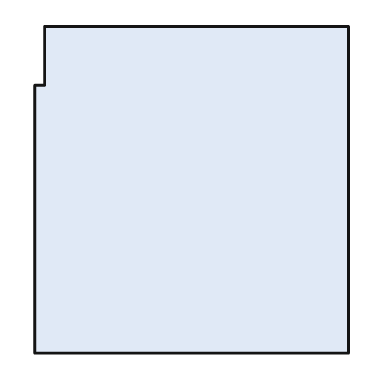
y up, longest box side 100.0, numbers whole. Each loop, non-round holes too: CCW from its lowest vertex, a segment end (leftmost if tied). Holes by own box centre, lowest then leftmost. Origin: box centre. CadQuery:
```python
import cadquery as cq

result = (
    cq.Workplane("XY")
    .moveTo(-48.0, -50.0)
    .lineTo(48.0, -50.0)
    .lineTo(48.0, 50.0)
    .lineTo(-45.0, 50.0)
    .lineTo(-45.0, 32.0)
    .lineTo(-48.0, 32.0)
    .close()
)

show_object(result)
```